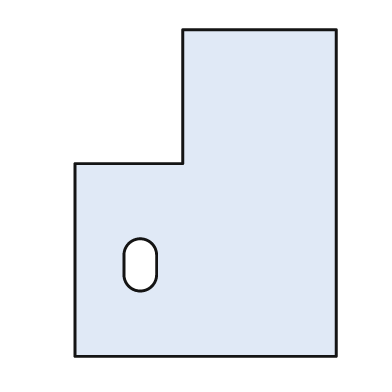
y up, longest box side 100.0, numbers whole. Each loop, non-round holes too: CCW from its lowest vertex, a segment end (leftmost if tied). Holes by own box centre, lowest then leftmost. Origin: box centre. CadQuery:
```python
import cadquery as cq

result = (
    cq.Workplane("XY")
    .moveTo(-40.0, -50.0)
    .lineTo(40.0, -50.0)
    .lineTo(40.0, 50.0)
    .lineTo(-7.0, 50.0)
    .lineTo(-7.0, 9.0)
    .lineTo(-40.0, 9.0)
    .close()
    .moveTo(-25.0, -25.0)
    .threePointArc((-20.0, -30.0), (-15.0, -25.0))
    .lineTo(-15.0, -19.0)
    .threePointArc((-20.0, -14.0), (-25.0, -19.0))
    .close()
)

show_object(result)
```